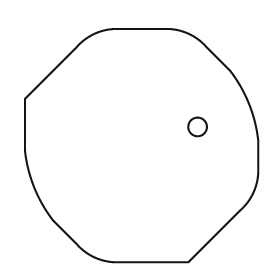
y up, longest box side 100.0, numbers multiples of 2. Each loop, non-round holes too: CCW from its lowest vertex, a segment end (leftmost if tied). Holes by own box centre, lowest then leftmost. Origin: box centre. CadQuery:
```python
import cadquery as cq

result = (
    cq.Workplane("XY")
    .moveTo(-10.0, -50.0)
    .lineTo(20.0, -50.0)
    .lineTo(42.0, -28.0)
    .threePointArc((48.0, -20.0), (50.0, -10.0))
    .lineTo(50.0, 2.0)
    .threePointArc((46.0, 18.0), (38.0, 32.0))
    .lineTo(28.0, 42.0)
    .threePointArc((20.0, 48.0), (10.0, 50.0))
    .lineTo(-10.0, 50.0)
    .threePointArc((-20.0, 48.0), (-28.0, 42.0))
    .lineTo(-50.0, 20.0)
    .lineTo(-50.0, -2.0)
    .threePointArc((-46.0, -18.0), (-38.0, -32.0))
    .lineTo(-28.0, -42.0)
    .threePointArc((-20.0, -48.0), (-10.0, -50.0))
    .close()
    .moveTo(24.0, 8.0)
    .circle(4.0)
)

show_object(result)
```